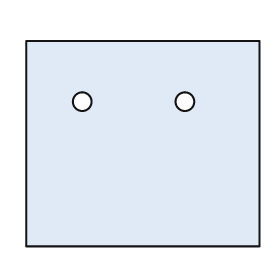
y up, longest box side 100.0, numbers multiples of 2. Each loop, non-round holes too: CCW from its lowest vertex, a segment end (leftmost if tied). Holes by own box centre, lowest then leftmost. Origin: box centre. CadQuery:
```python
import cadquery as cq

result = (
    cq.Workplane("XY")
    .moveTo(-50.0, -44.0)
    .lineTo(50.0, -44.0)
    .lineTo(50.0, 44.0)
    .lineTo(-50.0, 44.0)
    .close()
    .moveTo(-26.0, 18.0)
    .circle(4.0)
    .moveTo(18.0, 18.0)
    .circle(4.0)
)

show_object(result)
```